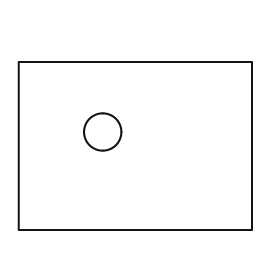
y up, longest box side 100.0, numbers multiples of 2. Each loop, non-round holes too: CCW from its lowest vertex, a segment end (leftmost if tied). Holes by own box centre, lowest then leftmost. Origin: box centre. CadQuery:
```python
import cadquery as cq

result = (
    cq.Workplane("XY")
    .moveTo(-50.0, -36.0)
    .lineTo(50.0, -36.0)
    .lineTo(50.0, 36.0)
    .lineTo(-50.0, 36.0)
    .close()
    .moveTo(-14.0, 6.0)
    .circle(8.0)
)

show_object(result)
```